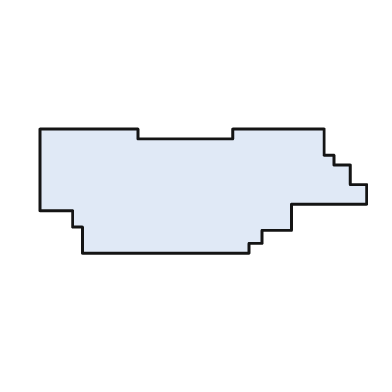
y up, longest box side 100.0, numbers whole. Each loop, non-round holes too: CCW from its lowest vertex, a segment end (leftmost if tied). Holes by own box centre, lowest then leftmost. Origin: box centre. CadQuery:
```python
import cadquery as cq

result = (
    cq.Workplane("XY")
    .moveTo(-37.0, -19.0)
    .lineTo(14.0, -19.0)
    .lineTo(14.0, -16.0)
    .lineTo(18.0, -16.0)
    .lineTo(18.0, -12.0)
    .lineTo(27.0, -12.0)
    .lineTo(27.0, -4.0)
    .lineTo(50.0, -4.0)
    .lineTo(50.0, 2.0)
    .lineTo(45.0, 2.0)
    .lineTo(45.0, 8.0)
    .lineTo(40.0, 8.0)
    .lineTo(40.0, 11.0)
    .lineTo(37.0, 11.0)
    .lineTo(37.0, 19.0)
    .lineTo(9.0, 19.0)
    .lineTo(9.0, 16.0)
    .lineTo(-20.0, 16.0)
    .lineTo(-20.0, 19.0)
    .lineTo(-50.0, 19.0)
    .lineTo(-50.0, -6.0)
    .lineTo(-40.0, -6.0)
    .lineTo(-40.0, -11.0)
    .lineTo(-37.0, -11.0)
    .close()
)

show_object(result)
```